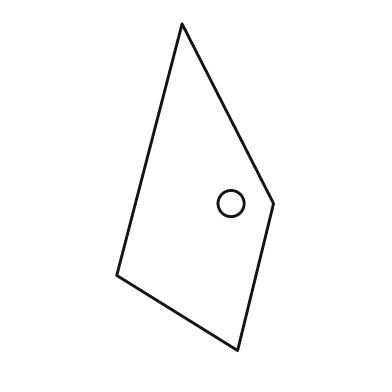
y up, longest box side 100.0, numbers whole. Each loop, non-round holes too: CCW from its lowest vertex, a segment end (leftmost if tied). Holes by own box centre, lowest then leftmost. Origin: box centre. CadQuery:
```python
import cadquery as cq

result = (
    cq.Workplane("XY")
    .moveTo(13.0, -50.0)
    .lineTo(24.0, -5.0)
    .lineTo(-4.0, 50.0)
    .lineTo(-24.0, -27.0)
    .close()
    .moveTo(11.0, -5.0)
    .circle(4.0)
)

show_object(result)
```